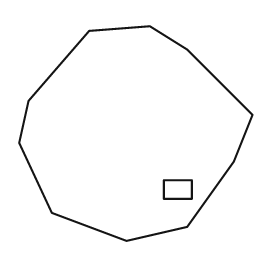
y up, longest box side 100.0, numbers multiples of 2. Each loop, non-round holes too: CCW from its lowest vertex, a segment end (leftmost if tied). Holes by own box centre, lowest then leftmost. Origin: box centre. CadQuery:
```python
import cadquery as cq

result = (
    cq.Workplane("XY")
    .moveTo(-4.0, -46.0)
    .lineTo(22.0, -40.0)
    .lineTo(42.0, -12.0)
    .lineTo(50.0, 8.0)
    .lineTo(22.0, 36.0)
    .lineTo(6.0, 46.0)
    .lineTo(-20.0, 44.0)
    .lineTo(-46.0, 14.0)
    .lineTo(-50.0, -4.0)
    .lineTo(-36.0, -34.0)
    .close()
    .moveTo(12.0, -28.0)
    .lineTo(24.0, -28.0)
    .lineTo(24.0, -20.0)
    .lineTo(12.0, -20.0)
    .close()
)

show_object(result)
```